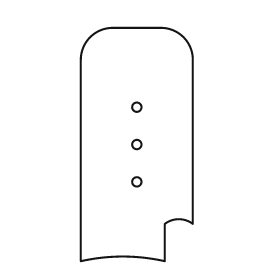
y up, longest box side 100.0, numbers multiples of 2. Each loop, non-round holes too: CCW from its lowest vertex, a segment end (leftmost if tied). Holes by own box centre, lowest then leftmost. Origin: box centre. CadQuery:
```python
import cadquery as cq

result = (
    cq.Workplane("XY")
    .moveTo(-24.0, -50.0)
    .threePointArc((-6.0, -48.0), (12.0, -50.0))
    .lineTo(12.0, -34.0)
    .threePointArc((18.0, -32.0), (24.0, -34.0))
    .lineTo(24.0, 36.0)
    .threePointArc((20.0, 46.0), (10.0, 50.0))
    .lineTo(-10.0, 50.0)
    .threePointArc((-20.0, 46.0), (-24.0, 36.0))
    .close()
    .moveTo(0.0, -16.0)
    .circle(2.0)
    .moveTo(0.0, 0.0)
    .circle(2.0)
    .moveTo(0.0, 16.0)
    .circle(2.0)
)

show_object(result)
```